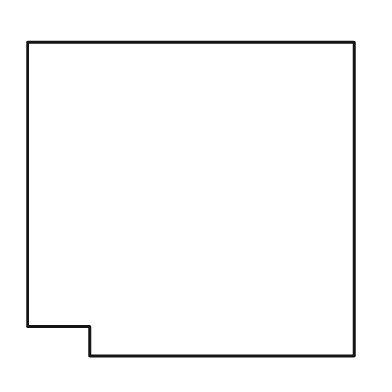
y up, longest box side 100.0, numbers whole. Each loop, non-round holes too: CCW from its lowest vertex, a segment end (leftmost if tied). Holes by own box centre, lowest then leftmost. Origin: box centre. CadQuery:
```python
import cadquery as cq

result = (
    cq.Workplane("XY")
    .moveTo(-31.0, -48.0)
    .lineTo(50.0, -48.0)
    .lineTo(50.0, 48.0)
    .lineTo(-50.0, 48.0)
    .lineTo(-50.0, -39.0)
    .lineTo(-31.0, -39.0)
    .close()
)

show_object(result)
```